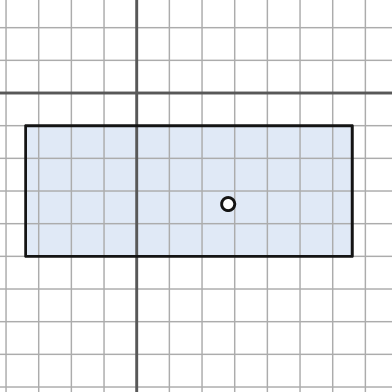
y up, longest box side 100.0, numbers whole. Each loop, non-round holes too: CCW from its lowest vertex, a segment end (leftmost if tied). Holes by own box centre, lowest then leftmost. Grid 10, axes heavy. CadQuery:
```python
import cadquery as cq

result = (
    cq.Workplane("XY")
    .moveTo(-34.0, -50.0)
    .lineTo(66.0, -50.0)
    .lineTo(66.0, -10.0)
    .lineTo(-34.0, -10.0)
    .close()
    .moveTo(28.0, -34.0)
    .circle(2.0)
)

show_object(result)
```